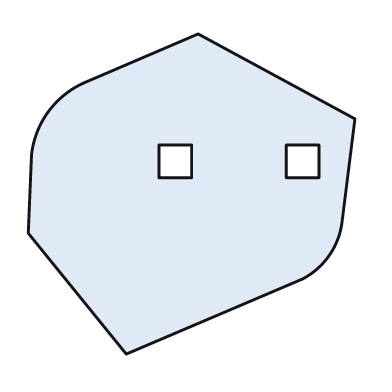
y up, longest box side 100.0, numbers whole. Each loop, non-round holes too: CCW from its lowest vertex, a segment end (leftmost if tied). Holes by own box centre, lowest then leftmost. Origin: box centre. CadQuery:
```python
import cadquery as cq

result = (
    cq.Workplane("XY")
    .moveTo(-20.0, -49.0)
    .lineTo(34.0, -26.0)
    .threePointArc((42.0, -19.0), (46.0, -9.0))
    .lineTo(50.0, 23.0)
    .lineTo(2.0, 49.0)
    .lineTo(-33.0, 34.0)
    .threePointArc((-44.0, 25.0), (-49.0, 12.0))
    .lineTo(-50.0, -12.0)
    .close()
    .moveTo(-10.0, 5.0)
    .lineTo(0.0, 5.0)
    .lineTo(0.0, 15.0)
    .lineTo(-10.0, 15.0)
    .close()
    .moveTo(29.0, 5.0)
    .lineTo(39.0, 5.0)
    .lineTo(39.0, 15.0)
    .lineTo(29.0, 15.0)
    .close()
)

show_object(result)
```